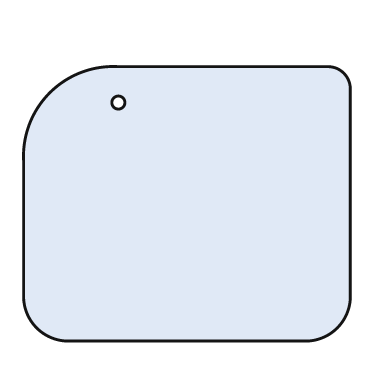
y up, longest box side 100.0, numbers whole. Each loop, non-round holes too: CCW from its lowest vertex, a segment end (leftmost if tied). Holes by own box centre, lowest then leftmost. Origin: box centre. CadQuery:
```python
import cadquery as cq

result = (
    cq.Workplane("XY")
    .moveTo(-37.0, -42.0)
    .lineTo(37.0, -42.0)
    .threePointArc((46.0, -38.0), (50.0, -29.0))
    .lineTo(50.0, 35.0)
    .threePointArc((48.0, 40.0), (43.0, 42.0))
    .lineTo(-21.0, 42.0)
    .threePointArc((-42.0, 34.0), (-50.0, 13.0))
    .lineTo(-50.0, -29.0)
    .threePointArc((-46.0, -38.0), (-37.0, -42.0))
    .close()
    .moveTo(-21.0, 31.0)
    .circle(2.0)
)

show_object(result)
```